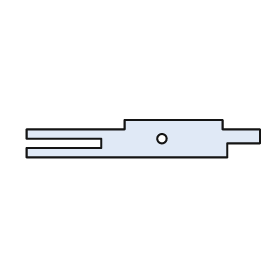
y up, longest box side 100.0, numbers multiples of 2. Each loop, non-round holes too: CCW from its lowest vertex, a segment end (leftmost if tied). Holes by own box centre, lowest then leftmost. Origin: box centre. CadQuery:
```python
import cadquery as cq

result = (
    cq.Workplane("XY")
    .moveTo(-50.0, -8.0)
    .lineTo(36.0, -8.0)
    .lineTo(36.0, -2.0)
    .lineTo(50.0, -2.0)
    .lineTo(50.0, 4.0)
    .lineTo(34.0, 4.0)
    .lineTo(34.0, 8.0)
    .lineTo(-8.0, 8.0)
    .lineTo(-8.0, 4.0)
    .lineTo(-50.0, 4.0)
    .lineTo(-50.0, 0.0)
    .lineTo(-18.0, 0.0)
    .lineTo(-18.0, -4.0)
    .lineTo(-50.0, -4.0)
    .close()
    .moveTo(8.0, 0.0)
    .circle(2.0)
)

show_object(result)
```